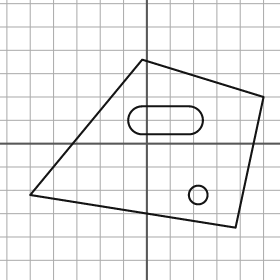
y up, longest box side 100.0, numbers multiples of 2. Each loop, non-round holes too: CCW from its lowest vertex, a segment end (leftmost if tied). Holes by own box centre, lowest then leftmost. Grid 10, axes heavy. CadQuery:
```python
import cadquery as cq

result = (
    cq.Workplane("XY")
    .moveTo(38.0, -36.0)
    .lineTo(50.0, 20.0)
    .lineTo(-2.0, 36.0)
    .lineTo(-50.0, -22.0)
    .close()
    .moveTo(22.0, -22.0)
    .circle(4.0)
    .moveTo(-2.0, 4.0)
    .lineTo(18.0, 4.0)
    .threePointArc((24.0, 10.0), (18.0, 16.0))
    .lineTo(-2.0, 16.0)
    .threePointArc((-8.0, 10.0), (-2.0, 4.0))
    .close()
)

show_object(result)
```